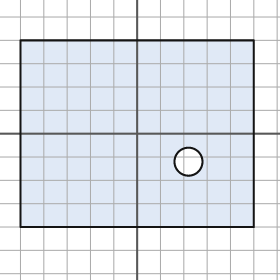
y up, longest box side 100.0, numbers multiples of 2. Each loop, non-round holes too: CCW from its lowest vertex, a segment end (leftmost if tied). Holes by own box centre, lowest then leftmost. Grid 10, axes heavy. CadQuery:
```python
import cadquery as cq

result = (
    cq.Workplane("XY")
    .moveTo(-50.0, -40.0)
    .lineTo(50.0, -40.0)
    .lineTo(50.0, 40.0)
    .lineTo(-50.0, 40.0)
    .close()
    .moveTo(22.0, -12.0)
    .circle(6.0)
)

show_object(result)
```